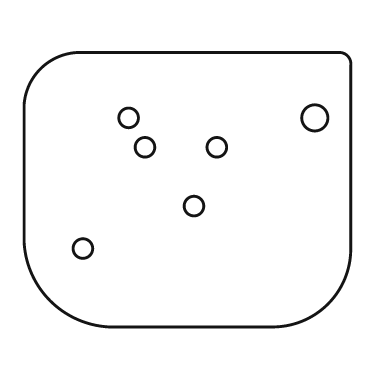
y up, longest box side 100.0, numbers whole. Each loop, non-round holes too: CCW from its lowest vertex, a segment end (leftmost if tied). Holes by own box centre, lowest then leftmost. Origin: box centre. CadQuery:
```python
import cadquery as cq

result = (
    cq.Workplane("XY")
    .moveTo(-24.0, -42.0)
    .lineTo(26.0, -42.0)
    .threePointArc((43.0, -35.0), (50.0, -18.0))
    .lineTo(50.0, 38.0)
    .threePointArc((49.0, 41.0), (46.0, 42.0))
    .lineTo(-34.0, 42.0)
    .threePointArc((-45.0, 37.0), (-50.0, 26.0))
    .lineTo(-50.0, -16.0)
    .threePointArc((-42.0, -34.0), (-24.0, -42.0))
    .close()
    .moveTo(-32.0, -18.0)
    .circle(3.0)
    .moveTo(2.0, -5.0)
    .circle(3.0)
    .moveTo(-13.0, 13.0)
    .circle(3.0)
    .moveTo(9.0, 13.0)
    .circle(3.0)
    .moveTo(-18.0, 22.0)
    .circle(3.0)
    .moveTo(39.0, 22.0)
    .circle(4.0)
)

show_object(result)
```